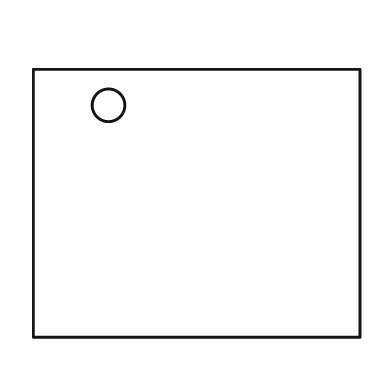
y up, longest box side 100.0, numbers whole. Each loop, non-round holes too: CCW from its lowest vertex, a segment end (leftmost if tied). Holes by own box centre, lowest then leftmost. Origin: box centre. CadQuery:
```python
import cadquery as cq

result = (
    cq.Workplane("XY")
    .moveTo(-50.0, -41.0)
    .lineTo(50.0, -41.0)
    .lineTo(50.0, 41.0)
    .lineTo(-50.0, 41.0)
    .close()
    .moveTo(-27.0, 30.0)
    .circle(5.0)
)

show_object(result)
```